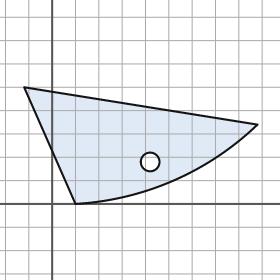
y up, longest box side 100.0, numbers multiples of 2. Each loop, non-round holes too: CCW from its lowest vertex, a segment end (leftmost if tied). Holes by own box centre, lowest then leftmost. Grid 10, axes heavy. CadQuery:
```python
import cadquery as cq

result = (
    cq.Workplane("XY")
    .moveTo(10.0, 0.0)
    .threePointArc((52.0, 10.0), (88.0, 34.0))
    .lineTo(-12.0, 50.0)
    .close()
    .moveTo(42.0, 18.0)
    .circle(4.0)
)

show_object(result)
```